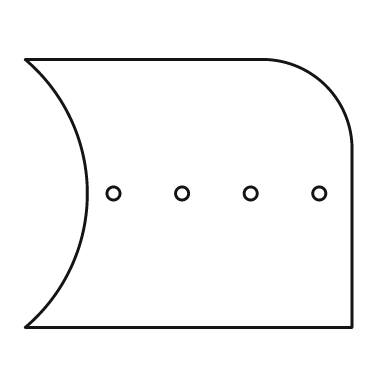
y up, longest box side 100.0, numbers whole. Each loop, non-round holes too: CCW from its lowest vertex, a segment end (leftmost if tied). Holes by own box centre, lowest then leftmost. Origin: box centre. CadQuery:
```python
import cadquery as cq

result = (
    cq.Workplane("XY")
    .moveTo(-50.0, -41.0)
    .lineTo(50.0, -41.0)
    .lineTo(50.0, 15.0)
    .threePointArc((42.0, 33.0), (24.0, 41.0))
    .lineTo(-50.0, 41.0)
    .threePointArc((-31.0, 0.0), (-50.0, -41.0))
    .close()
    .moveTo(-23.0, 0.0)
    .circle(2.0)
    .moveTo(-2.0, 0.0)
    .circle(2.0)
    .moveTo(19.0, 0.0)
    .circle(2.0)
    .moveTo(40.0, 0.0)
    .circle(2.0)
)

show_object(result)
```